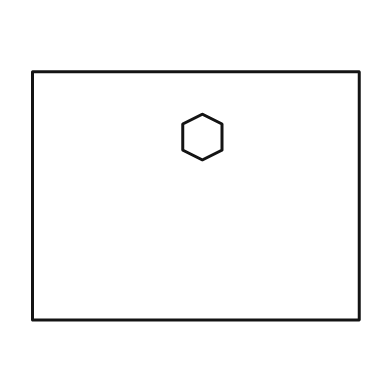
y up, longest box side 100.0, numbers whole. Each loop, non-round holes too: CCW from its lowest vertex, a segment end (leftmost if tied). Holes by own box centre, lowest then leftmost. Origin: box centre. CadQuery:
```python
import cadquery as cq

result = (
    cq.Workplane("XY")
    .moveTo(-50.0, -38.0)
    .lineTo(50.0, -38.0)
    .lineTo(50.0, 38.0)
    .lineTo(-50.0, 38.0)
    .close()
    .moveTo(2.0, 11.0)
    .lineTo(8.0, 14.0)
    .lineTo(8.0, 22.0)
    .lineTo(2.0, 25.0)
    .lineTo(-4.0, 22.0)
    .lineTo(-4.0, 14.0)
    .close()
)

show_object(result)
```